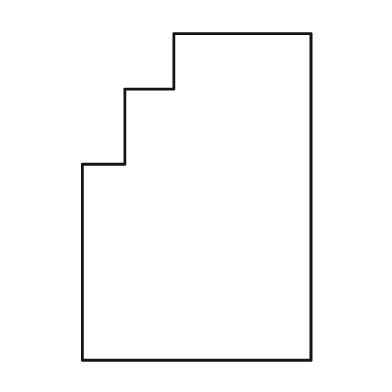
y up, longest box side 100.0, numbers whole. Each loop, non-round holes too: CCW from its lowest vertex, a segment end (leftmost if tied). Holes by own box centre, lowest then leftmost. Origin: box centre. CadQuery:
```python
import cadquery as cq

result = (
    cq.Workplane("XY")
    .moveTo(-35.0, -50.0)
    .lineTo(35.0, -50.0)
    .lineTo(35.0, 50.0)
    .lineTo(-7.0, 50.0)
    .lineTo(-7.0, 33.0)
    .lineTo(-22.0, 33.0)
    .lineTo(-22.0, 10.0)
    .lineTo(-35.0, 10.0)
    .close()
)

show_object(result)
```